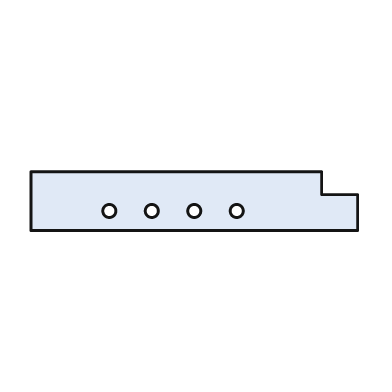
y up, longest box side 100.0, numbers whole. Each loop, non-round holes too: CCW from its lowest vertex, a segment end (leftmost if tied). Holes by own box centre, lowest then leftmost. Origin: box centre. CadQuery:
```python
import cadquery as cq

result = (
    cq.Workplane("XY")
    .moveTo(-50.0, -9.0)
    .lineTo(50.0, -9.0)
    .lineTo(50.0, 2.0)
    .lineTo(39.0, 2.0)
    .lineTo(39.0, 9.0)
    .lineTo(-50.0, 9.0)
    .close()
    .moveTo(-26.0, -3.0)
    .circle(2.0)
    .moveTo(-13.0, -3.0)
    .circle(2.0)
    .moveTo(0.0, -3.0)
    .circle(2.0)
    .moveTo(13.0, -3.0)
    .circle(2.0)
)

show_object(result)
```